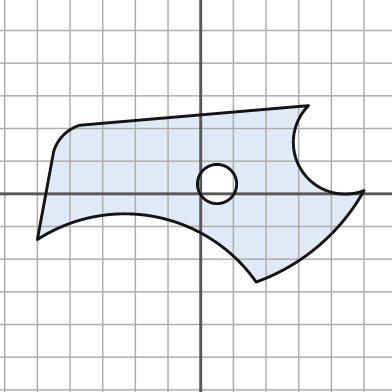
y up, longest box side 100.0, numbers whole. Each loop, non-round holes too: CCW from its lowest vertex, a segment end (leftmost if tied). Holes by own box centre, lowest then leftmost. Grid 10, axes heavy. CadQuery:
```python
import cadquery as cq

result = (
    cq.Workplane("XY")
    .moveTo(17.0, -27.0)
    .threePointArc((36.0, -16.0), (50.0, 1.0))
    .threePointArc((31.0, 7.0), (33.0, 27.0))
    .lineTo(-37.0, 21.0)
    .threePointArc((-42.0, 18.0), (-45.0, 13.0))
    .lineTo(-50.0, -14.0)
    .threePointArc((-14.0, -7.0), (17.0, -27.0))
    .close()
    .moveTo(5.0, 3.0)
    .circle(6.0)
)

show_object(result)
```